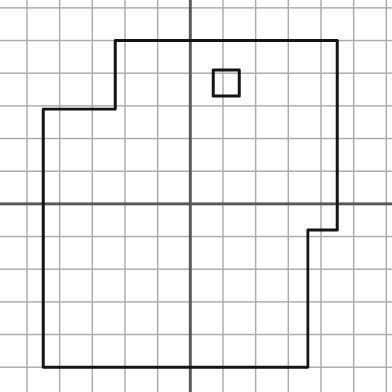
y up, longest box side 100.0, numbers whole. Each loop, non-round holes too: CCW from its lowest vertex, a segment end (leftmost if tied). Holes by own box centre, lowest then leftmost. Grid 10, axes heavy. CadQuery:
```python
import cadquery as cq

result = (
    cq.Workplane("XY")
    .moveTo(-45.0, -50.0)
    .lineTo(36.0, -50.0)
    .lineTo(36.0, -8.0)
    .lineTo(45.0, -8.0)
    .lineTo(45.0, 50.0)
    .lineTo(-23.0, 50.0)
    .lineTo(-23.0, 29.0)
    .lineTo(-45.0, 29.0)
    .close()
    .moveTo(7.0, 33.0)
    .lineTo(15.0, 33.0)
    .lineTo(15.0, 41.0)
    .lineTo(7.0, 41.0)
    .close()
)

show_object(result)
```